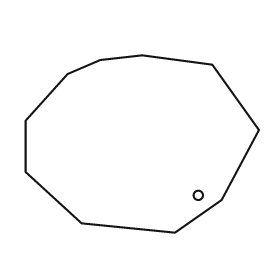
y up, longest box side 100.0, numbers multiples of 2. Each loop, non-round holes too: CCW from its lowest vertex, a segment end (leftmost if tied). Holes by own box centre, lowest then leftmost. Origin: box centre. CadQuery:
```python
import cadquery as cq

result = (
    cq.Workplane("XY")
    .moveTo(14.0, -38.0)
    .lineTo(34.0, -24.0)
    .lineTo(50.0, 6.0)
    .lineTo(30.0, 34.0)
    .lineTo(0.0, 38.0)
    .lineTo(-18.0, 36.0)
    .lineTo(-32.0, 30.0)
    .lineTo(-50.0, 10.0)
    .lineTo(-50.0, -12.0)
    .lineTo(-26.0, -34.0)
    .close()
    .moveTo(24.0, -22.0)
    .circle(2.0)
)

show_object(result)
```